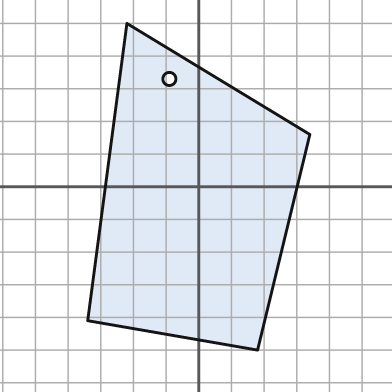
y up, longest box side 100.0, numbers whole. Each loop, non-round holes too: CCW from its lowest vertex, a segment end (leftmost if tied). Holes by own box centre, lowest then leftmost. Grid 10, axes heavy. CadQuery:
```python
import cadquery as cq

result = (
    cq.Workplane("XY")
    .moveTo(18.0, -50.0)
    .lineTo(34.0, 16.0)
    .lineTo(-22.0, 50.0)
    .lineTo(-34.0, -41.0)
    .close()
    .moveTo(-9.0, 33.0)
    .circle(2.0)
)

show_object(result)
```